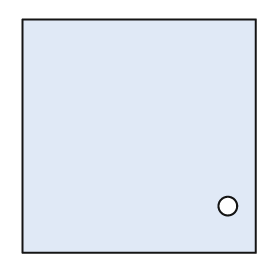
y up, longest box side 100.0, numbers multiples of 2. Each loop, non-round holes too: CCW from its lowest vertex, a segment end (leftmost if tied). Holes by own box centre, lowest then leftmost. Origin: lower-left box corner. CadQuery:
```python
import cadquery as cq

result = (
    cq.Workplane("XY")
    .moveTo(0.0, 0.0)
    .lineTo(100.0, 0.0)
    .lineTo(100.0, 100.0)
    .lineTo(0.0, 100.0)
    .close()
    .moveTo(88.0, 20.0)
    .circle(4.0)
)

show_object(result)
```